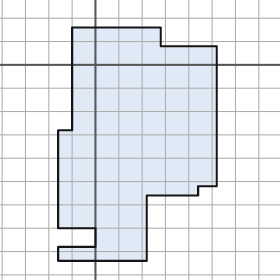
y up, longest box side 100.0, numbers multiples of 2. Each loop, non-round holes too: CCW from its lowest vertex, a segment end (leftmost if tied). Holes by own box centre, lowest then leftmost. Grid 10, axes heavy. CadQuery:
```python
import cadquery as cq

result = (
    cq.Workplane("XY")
    .moveTo(-16.0, -84.0)
    .lineTo(22.0, -84.0)
    .lineTo(22.0, -56.0)
    .lineTo(44.0, -56.0)
    .lineTo(44.0, -52.0)
    .lineTo(52.0, -52.0)
    .lineTo(52.0, 8.0)
    .lineTo(28.0, 8.0)
    .lineTo(28.0, 16.0)
    .lineTo(-10.0, 16.0)
    .lineTo(-10.0, -28.0)
    .lineTo(-16.0, -28.0)
    .lineTo(-16.0, -70.0)
    .lineTo(0.0, -70.0)
    .lineTo(0.0, -78.0)
    .lineTo(-16.0, -78.0)
    .close()
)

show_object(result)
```